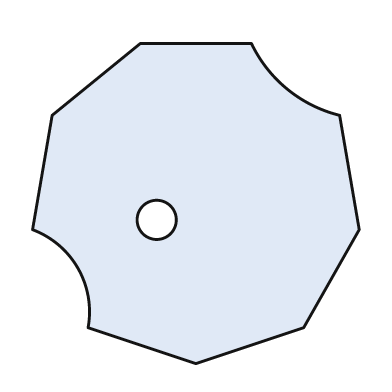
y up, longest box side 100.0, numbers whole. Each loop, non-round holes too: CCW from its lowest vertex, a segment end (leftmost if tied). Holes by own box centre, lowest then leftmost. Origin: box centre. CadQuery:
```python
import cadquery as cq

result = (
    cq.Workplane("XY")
    .moveTo(0.0, -49.0)
    .lineTo(33.0, -38.0)
    .lineTo(50.0, -8.0)
    .lineTo(44.0, 27.0)
    .threePointArc((28.0, 35.0), (17.0, 49.0))
    .lineTo(-17.0, 49.0)
    .lineTo(-44.0, 27.0)
    .lineTo(-50.0, -8.0)
    .threePointArc((-36.0, -20.0), (-33.0, -38.0))
    .close()
    .moveTo(-12.0, -5.0)
    .circle(6.0)
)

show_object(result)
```